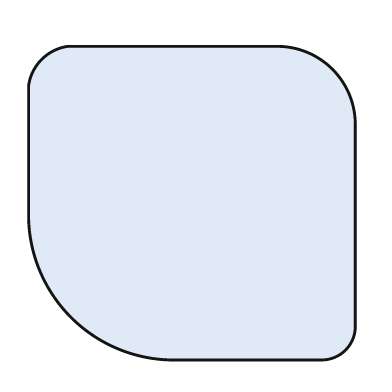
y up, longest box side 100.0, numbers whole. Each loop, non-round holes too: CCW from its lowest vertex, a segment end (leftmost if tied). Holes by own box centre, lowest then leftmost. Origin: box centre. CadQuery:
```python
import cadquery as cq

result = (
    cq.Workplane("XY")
    .moveTo(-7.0, -48.0)
    .lineTo(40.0, -48.0)
    .threePointArc((47.0, -45.0), (50.0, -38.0))
    .lineTo(50.0, 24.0)
    .threePointArc((43.0, 41.0), (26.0, 48.0))
    .lineTo(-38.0, 48.0)
    .threePointArc((-46.0, 44.0), (-50.0, 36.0))
    .lineTo(-50.0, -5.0)
    .threePointArc((-37.0, -35.0), (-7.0, -48.0))
    .close()
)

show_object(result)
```